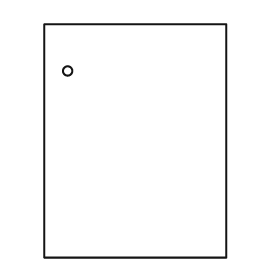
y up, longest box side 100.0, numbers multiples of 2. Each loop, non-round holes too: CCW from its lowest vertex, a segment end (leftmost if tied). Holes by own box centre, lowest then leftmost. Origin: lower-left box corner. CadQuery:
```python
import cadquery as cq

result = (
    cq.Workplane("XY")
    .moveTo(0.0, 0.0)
    .lineTo(78.0, 0.0)
    .lineTo(78.0, 100.0)
    .lineTo(0.0, 100.0)
    .close()
    .moveTo(10.0, 80.0)
    .circle(2.0)
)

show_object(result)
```